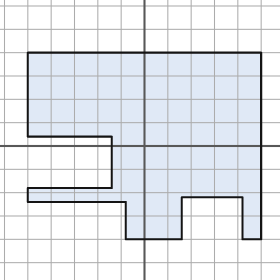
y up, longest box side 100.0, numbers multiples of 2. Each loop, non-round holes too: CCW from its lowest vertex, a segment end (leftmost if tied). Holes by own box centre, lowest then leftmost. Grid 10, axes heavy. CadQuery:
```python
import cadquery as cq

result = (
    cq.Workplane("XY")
    .moveTo(-8.0, -40.0)
    .lineTo(16.0, -40.0)
    .lineTo(16.0, -22.0)
    .lineTo(42.0, -22.0)
    .lineTo(42.0, -40.0)
    .lineTo(50.0, -40.0)
    .lineTo(50.0, 40.0)
    .lineTo(-50.0, 40.0)
    .lineTo(-50.0, 4.0)
    .lineTo(-14.0, 4.0)
    .lineTo(-14.0, -18.0)
    .lineTo(-50.0, -18.0)
    .lineTo(-50.0, -24.0)
    .lineTo(-8.0, -24.0)
    .close()
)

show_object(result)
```